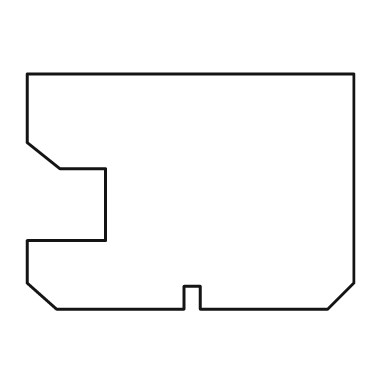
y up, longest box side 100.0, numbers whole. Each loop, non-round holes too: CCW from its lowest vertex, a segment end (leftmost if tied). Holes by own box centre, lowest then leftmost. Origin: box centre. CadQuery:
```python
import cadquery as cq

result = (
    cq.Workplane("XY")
    .moveTo(-41.0, -36.0)
    .lineTo(-2.0, -36.0)
    .lineTo(-2.0, -29.0)
    .lineTo(3.0, -29.0)
    .lineTo(3.0, -36.0)
    .lineTo(42.0, -36.0)
    .lineTo(50.0, -28.0)
    .lineTo(50.0, 36.0)
    .lineTo(-50.0, 36.0)
    .lineTo(-50.0, 15.0)
    .lineTo(-40.0, 7.0)
    .lineTo(-26.0, 7.0)
    .lineTo(-26.0, -15.0)
    .lineTo(-50.0, -15.0)
    .lineTo(-50.0, -28.0)
    .close()
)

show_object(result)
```